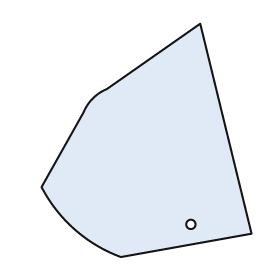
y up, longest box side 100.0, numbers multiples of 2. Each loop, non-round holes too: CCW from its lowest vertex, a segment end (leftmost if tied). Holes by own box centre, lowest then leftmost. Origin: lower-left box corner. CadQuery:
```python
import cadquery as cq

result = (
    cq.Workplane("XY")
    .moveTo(34.0, 0.0)
    .lineTo(90.0, 10.0)
    .lineTo(68.0, 100.0)
    .lineTo(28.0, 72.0)
    .threePointArc((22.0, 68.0), (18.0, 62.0))
    .lineTo(0.0, 30.0)
    .threePointArc((14.0, 12.0), (34.0, 0.0))
    .close()
    .moveTo(64.0, 14.0)
    .circle(2.0)
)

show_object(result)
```